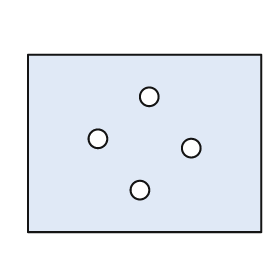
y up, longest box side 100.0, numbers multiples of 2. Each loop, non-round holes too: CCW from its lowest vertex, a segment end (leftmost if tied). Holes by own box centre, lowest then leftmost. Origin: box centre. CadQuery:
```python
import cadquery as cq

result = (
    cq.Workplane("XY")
    .moveTo(-50.0, -38.0)
    .lineTo(50.0, -38.0)
    .lineTo(50.0, 38.0)
    .lineTo(-50.0, 38.0)
    .close()
    .moveTo(-2.0, -20.0)
    .circle(4.0)
    .moveTo(20.0, -2.0)
    .circle(4.0)
    .moveTo(-20.0, 2.0)
    .circle(4.0)
    .moveTo(2.0, 20.0)
    .circle(4.0)
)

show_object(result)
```